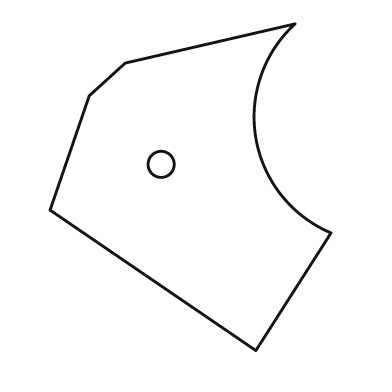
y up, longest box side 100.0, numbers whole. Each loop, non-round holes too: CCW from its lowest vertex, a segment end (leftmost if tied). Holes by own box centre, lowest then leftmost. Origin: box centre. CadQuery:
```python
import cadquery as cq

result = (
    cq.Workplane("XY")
    .moveTo(20.0, -50.0)
    .lineTo(43.0, -14.0)
    .threePointArc((20.0, 15.0), (32.0, 50.0))
    .lineTo(-20.0, 38.0)
    .lineTo(-31.0, 28.0)
    .lineTo(-43.0, -7.0)
    .close()
    .moveTo(-9.0, 7.0)
    .circle(4.0)
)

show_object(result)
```